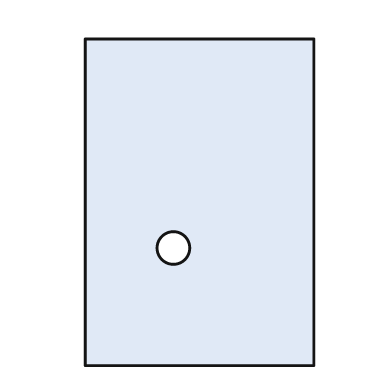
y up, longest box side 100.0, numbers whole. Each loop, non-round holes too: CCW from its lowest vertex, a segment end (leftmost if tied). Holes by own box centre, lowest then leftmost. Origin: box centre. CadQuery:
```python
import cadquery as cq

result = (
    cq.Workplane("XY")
    .moveTo(-35.0, -50.0)
    .lineTo(35.0, -50.0)
    .lineTo(35.0, 50.0)
    .lineTo(-35.0, 50.0)
    .close()
    .moveTo(-8.0, -14.0)
    .circle(5.0)
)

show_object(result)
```